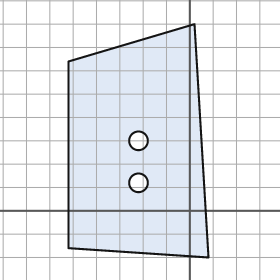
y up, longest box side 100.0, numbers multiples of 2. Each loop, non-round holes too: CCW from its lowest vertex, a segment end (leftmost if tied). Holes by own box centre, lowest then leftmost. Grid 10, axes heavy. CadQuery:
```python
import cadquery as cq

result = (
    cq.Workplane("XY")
    .moveTo(8.0, -20.0)
    .lineTo(2.0, 80.0)
    .lineTo(-52.0, 64.0)
    .lineTo(-52.0, -16.0)
    .close()
    .moveTo(-22.0, 12.0)
    .circle(4.0)
    .moveTo(-22.0, 30.0)
    .circle(4.0)
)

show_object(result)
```